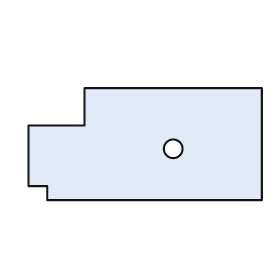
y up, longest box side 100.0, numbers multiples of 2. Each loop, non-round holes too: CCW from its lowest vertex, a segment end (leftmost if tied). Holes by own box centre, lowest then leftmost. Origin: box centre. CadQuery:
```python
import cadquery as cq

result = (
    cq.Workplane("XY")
    .moveTo(-42.0, -24.0)
    .lineTo(50.0, -24.0)
    .lineTo(50.0, 24.0)
    .lineTo(-26.0, 24.0)
    .lineTo(-26.0, 8.0)
    .lineTo(-50.0, 8.0)
    .lineTo(-50.0, -18.0)
    .lineTo(-42.0, -18.0)
    .close()
    .moveTo(12.0, -2.0)
    .circle(4.0)
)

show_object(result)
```